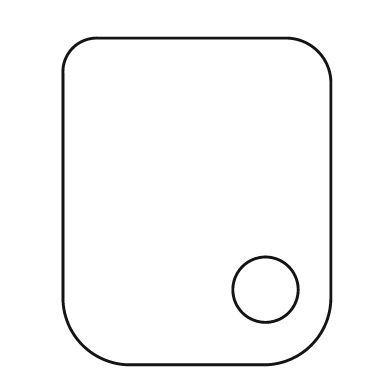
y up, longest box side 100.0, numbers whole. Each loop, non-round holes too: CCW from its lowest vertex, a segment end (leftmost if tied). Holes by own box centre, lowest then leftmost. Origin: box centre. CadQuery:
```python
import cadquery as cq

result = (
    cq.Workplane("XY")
    .moveTo(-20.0, -50.0)
    .lineTo(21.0, -50.0)
    .threePointArc((35.0, -44.0), (41.0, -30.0))
    .lineTo(41.0, 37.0)
    .threePointArc((37.0, 46.0), (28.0, 50.0))
    .lineTo(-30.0, 50.0)
    .threePointArc((-38.0, 47.0), (-41.0, 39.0))
    .lineTo(-41.0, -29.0)
    .threePointArc((-35.0, -44.0), (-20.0, -50.0))
    .close()
    .moveTo(21.0, -27.0)
    .circle(10.0)
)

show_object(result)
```